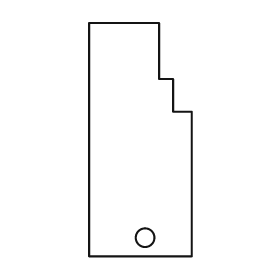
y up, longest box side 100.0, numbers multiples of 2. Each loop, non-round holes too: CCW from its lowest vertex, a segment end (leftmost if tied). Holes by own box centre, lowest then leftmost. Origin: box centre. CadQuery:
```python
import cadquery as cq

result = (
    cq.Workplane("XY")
    .moveTo(-22.0, -50.0)
    .lineTo(22.0, -50.0)
    .lineTo(22.0, 12.0)
    .lineTo(14.0, 12.0)
    .lineTo(14.0, 26.0)
    .lineTo(8.0, 26.0)
    .lineTo(8.0, 50.0)
    .lineTo(-22.0, 50.0)
    .close()
    .moveTo(2.0, -42.0)
    .circle(4.0)
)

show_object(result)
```